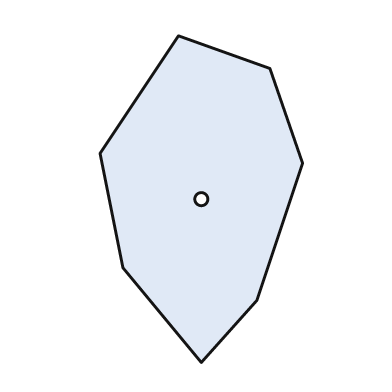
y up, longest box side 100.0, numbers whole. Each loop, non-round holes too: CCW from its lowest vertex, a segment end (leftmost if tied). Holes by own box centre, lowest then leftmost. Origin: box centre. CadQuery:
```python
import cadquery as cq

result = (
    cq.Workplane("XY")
    .moveTo(0.0, -50.0)
    .lineTo(17.0, -31.0)
    .lineTo(31.0, 11.0)
    .lineTo(21.0, 40.0)
    .lineTo(-7.0, 50.0)
    .lineTo(-31.0, 14.0)
    .lineTo(-24.0, -21.0)
    .close()
    .moveTo(0.0, 0.0)
    .circle(2.0)
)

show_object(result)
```